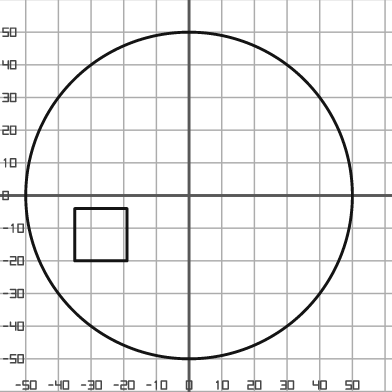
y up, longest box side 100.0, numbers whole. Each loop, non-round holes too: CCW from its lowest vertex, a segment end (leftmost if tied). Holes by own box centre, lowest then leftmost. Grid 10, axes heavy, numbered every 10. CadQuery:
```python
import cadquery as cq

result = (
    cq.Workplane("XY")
    .moveTo(0.0, 0.0)
    .circle(50.0)
    .moveTo(-35.0, -20.0)
    .lineTo(-19.0, -20.0)
    .lineTo(-19.0, -4.0)
    .lineTo(-35.0, -4.0)
    .close()
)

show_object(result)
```